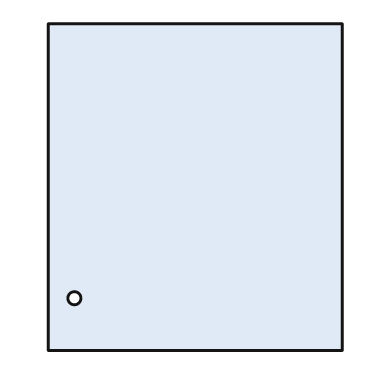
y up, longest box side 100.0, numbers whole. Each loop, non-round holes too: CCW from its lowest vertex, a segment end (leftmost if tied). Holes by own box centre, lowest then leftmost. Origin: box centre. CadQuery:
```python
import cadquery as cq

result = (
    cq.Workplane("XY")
    .moveTo(-45.0, -50.0)
    .lineTo(45.0, -50.0)
    .lineTo(45.0, 50.0)
    .lineTo(-45.0, 50.0)
    .close()
    .moveTo(-37.0, -34.0)
    .circle(2.0)
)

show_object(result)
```